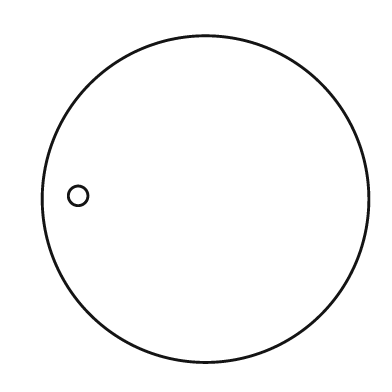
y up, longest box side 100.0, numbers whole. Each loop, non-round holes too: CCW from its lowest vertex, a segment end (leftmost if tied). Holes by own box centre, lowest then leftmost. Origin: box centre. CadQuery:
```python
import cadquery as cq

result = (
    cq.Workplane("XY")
    .moveTo(0.0, 0.0)
    .circle(50.0)
    .moveTo(-39.0, 1.0)
    .circle(3.0)
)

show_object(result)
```